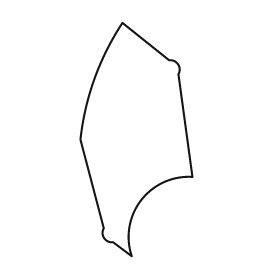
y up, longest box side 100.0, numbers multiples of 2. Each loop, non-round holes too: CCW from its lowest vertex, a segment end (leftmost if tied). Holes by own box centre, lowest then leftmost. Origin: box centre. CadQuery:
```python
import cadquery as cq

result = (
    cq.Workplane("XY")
    .moveTo(-2.0, -50.0)
    .threePointArc((2.0, -26.0), (24.0, -16.0))
    .lineTo(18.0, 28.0)
    .threePointArc((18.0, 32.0), (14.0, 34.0))
    .lineTo(-6.0, 50.0)
    .threePointArc((-18.0, 26.0), (-24.0, 0.0))
    .lineTo(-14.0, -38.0)
    .threePointArc((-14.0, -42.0), (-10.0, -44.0))
    .close()
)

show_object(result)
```